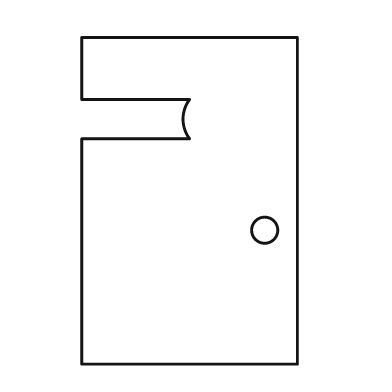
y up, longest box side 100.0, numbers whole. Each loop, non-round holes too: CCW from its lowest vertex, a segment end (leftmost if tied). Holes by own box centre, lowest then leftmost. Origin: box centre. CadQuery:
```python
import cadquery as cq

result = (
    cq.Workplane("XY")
    .moveTo(-33.0, -50.0)
    .lineTo(33.0, -50.0)
    .lineTo(33.0, 50.0)
    .lineTo(-33.0, 50.0)
    .lineTo(-33.0, 31.0)
    .lineTo(0.0, 31.0)
    .threePointArc((-2.0, 25.0), (0.0, 19.0))
    .lineTo(-33.0, 19.0)
    .close()
    .moveTo(23.0, -9.0)
    .circle(4.0)
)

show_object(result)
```